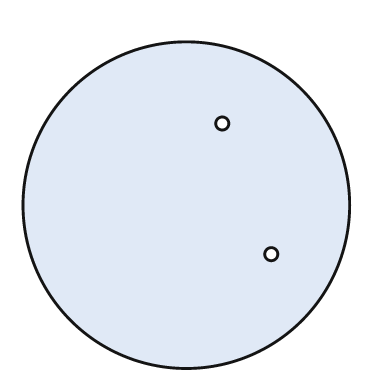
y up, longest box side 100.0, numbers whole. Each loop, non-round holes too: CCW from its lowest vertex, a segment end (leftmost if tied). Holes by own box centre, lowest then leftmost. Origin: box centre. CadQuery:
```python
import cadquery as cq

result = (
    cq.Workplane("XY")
    .moveTo(0.0, 0.0)
    .circle(50.0)
    .moveTo(26.0, -15.0)
    .circle(2.0)
    .moveTo(11.0, 25.0)
    .circle(2.0)
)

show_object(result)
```